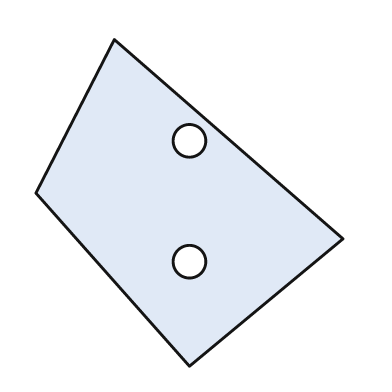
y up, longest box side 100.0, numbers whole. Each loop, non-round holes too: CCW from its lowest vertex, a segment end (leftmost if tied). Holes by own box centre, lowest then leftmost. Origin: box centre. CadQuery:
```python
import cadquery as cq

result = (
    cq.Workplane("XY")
    .moveTo(0.0, -50.0)
    .lineTo(47.0, -11.0)
    .lineTo(-23.0, 50.0)
    .lineTo(-47.0, 3.0)
    .close()
    .moveTo(0.0, -18.0)
    .circle(5.0)
    .moveTo(0.0, 19.0)
    .circle(5.0)
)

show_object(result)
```